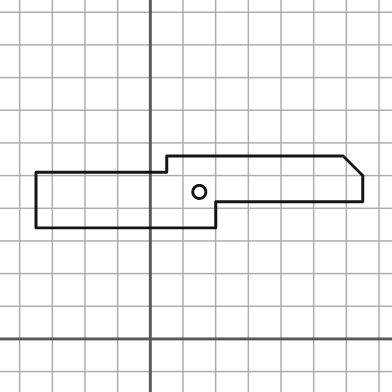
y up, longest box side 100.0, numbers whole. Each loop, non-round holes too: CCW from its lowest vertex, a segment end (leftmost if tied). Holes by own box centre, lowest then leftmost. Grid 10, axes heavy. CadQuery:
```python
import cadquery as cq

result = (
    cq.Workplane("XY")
    .moveTo(-35.0, 34.0)
    .lineTo(20.0, 34.0)
    .lineTo(20.0, 42.0)
    .lineTo(65.0, 42.0)
    .lineTo(65.0, 50.0)
    .lineTo(59.0, 56.0)
    .lineTo(5.0, 56.0)
    .lineTo(5.0, 51.0)
    .lineTo(-35.0, 51.0)
    .close()
    .moveTo(15.0, 45.0)
    .circle(2.0)
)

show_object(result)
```